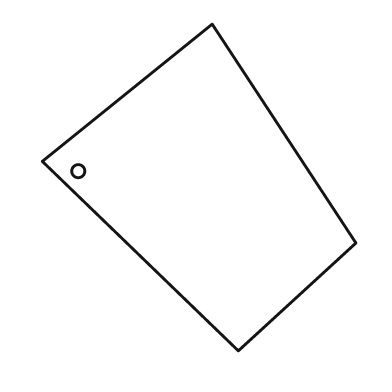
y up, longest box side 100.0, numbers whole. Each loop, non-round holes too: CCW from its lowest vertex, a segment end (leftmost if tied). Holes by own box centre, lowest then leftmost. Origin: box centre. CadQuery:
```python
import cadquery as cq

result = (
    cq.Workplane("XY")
    .moveTo(12.0, -50.0)
    .lineTo(48.0, -17.0)
    .lineTo(4.0, 50.0)
    .lineTo(-48.0, 8.0)
    .close()
    .moveTo(-37.0, 5.0)
    .circle(2.0)
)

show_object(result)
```